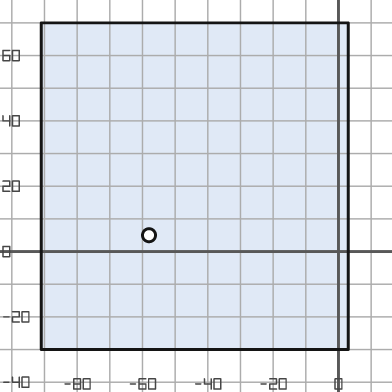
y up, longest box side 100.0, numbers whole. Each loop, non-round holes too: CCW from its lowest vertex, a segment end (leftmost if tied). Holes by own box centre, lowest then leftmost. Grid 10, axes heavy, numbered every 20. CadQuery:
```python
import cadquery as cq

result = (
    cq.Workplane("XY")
    .moveTo(-91.0, -30.0)
    .lineTo(3.0, -30.0)
    .lineTo(3.0, 70.0)
    .lineTo(-91.0, 70.0)
    .close()
    .moveTo(-58.0, 5.0)
    .circle(2.0)
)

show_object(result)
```